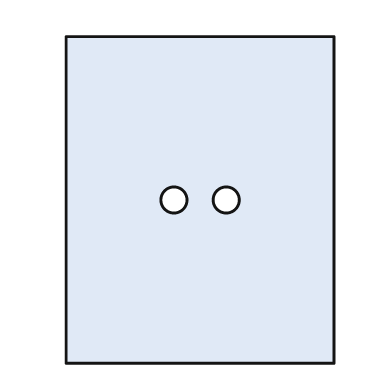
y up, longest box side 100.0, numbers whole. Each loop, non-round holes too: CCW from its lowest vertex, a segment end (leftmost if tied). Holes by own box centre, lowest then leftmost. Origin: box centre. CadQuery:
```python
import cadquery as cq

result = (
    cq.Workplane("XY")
    .moveTo(-41.0, -50.0)
    .lineTo(41.0, -50.0)
    .lineTo(41.0, 50.0)
    .lineTo(-41.0, 50.0)
    .close()
    .moveTo(-8.0, 0.0)
    .circle(4.0)
    .moveTo(8.0, 0.0)
    .circle(4.0)
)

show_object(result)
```